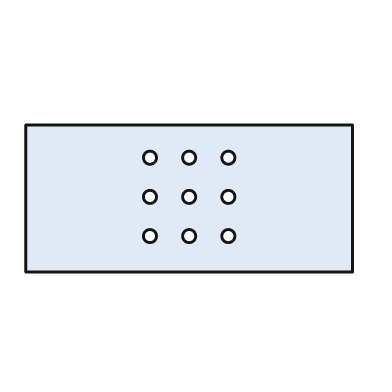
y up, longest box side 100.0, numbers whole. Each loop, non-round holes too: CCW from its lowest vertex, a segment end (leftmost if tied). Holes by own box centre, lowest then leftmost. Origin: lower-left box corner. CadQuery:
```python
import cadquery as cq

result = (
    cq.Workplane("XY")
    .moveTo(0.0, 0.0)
    .lineTo(100.0, 0.0)
    .lineTo(100.0, 45.0)
    .lineTo(0.0, 45.0)
    .close()
    .moveTo(38.0, 11.0)
    .circle(2.0)
    .moveTo(50.0, 11.0)
    .circle(2.0)
    .moveTo(62.0, 11.0)
    .circle(2.0)
    .moveTo(38.0, 23.0)
    .circle(2.0)
    .moveTo(50.0, 23.0)
    .circle(2.0)
    .moveTo(62.0, 23.0)
    .circle(2.0)
    .moveTo(38.0, 35.0)
    .circle(2.0)
    .moveTo(50.0, 35.0)
    .circle(2.0)
    .moveTo(62.0, 35.0)
    .circle(2.0)
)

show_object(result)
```